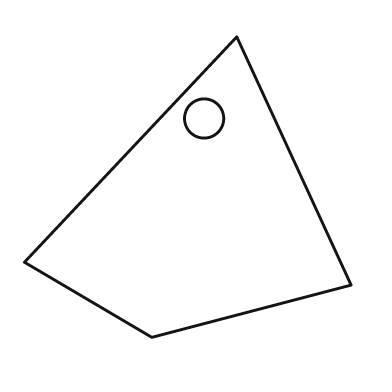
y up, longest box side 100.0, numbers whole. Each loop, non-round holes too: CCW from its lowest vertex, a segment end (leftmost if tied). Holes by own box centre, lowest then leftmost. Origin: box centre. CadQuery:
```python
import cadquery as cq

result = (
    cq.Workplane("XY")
    .moveTo(-11.0, -46.0)
    .lineTo(50.0, -30.0)
    .lineTo(15.0, 46.0)
    .lineTo(-50.0, -23.0)
    .close()
    .moveTo(5.0, 21.0)
    .circle(6.0)
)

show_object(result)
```